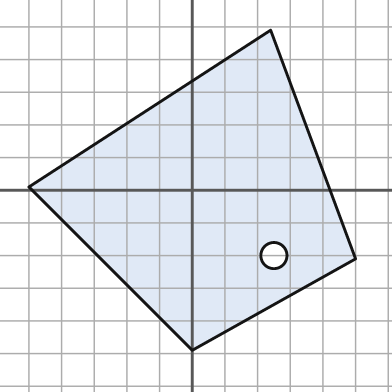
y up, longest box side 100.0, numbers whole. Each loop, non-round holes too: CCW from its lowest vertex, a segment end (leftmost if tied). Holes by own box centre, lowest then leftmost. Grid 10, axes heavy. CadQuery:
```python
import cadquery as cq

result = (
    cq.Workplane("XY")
    .moveTo(0.0, -49.0)
    .lineTo(50.0, -21.0)
    .lineTo(24.0, 49.0)
    .lineTo(-50.0, 1.0)
    .close()
    .moveTo(25.0, -20.0)
    .circle(4.0)
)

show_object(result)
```